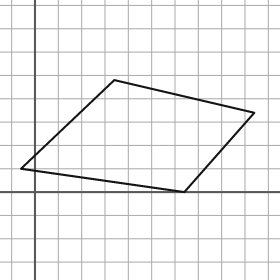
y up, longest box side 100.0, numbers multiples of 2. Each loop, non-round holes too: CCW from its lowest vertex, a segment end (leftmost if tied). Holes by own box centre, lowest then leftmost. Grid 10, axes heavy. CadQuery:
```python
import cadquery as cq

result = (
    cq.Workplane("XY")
    .moveTo(64.0, 0.0)
    .lineTo(94.0, 34.0)
    .lineTo(34.0, 48.0)
    .lineTo(-6.0, 10.0)
    .close()
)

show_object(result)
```